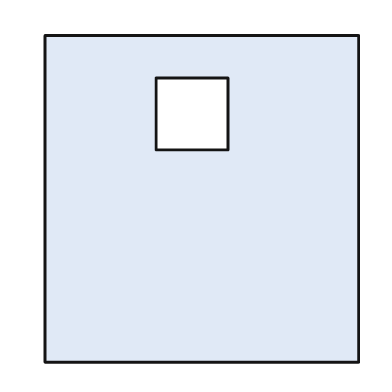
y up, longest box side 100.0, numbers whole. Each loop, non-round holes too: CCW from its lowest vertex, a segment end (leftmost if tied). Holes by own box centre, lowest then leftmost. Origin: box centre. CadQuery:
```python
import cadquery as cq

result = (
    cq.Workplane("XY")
    .moveTo(-48.0, -50.0)
    .lineTo(48.0, -50.0)
    .lineTo(48.0, 50.0)
    .lineTo(-48.0, 50.0)
    .close()
    .moveTo(-14.0, 15.0)
    .lineTo(8.0, 15.0)
    .lineTo(8.0, 37.0)
    .lineTo(-14.0, 37.0)
    .close()
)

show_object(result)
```